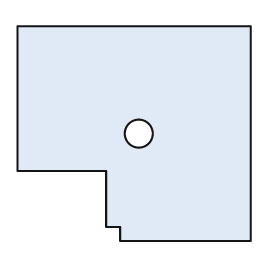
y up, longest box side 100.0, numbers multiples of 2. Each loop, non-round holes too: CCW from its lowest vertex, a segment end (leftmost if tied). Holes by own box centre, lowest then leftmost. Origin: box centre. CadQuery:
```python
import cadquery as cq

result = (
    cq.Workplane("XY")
    .moveTo(-6.0, -46.0)
    .lineTo(50.0, -46.0)
    .lineTo(50.0, 46.0)
    .lineTo(-50.0, 46.0)
    .lineTo(-50.0, -16.0)
    .lineTo(-12.0, -16.0)
    .lineTo(-12.0, -40.0)
    .lineTo(-6.0, -40.0)
    .close()
    .moveTo(2.0, 0.0)
    .circle(6.0)
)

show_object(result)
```